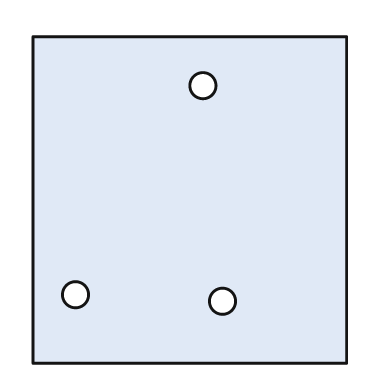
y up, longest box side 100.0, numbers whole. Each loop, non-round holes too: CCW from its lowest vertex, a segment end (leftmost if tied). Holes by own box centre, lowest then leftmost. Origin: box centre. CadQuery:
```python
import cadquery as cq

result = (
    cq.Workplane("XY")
    .moveTo(-48.0, -50.0)
    .lineTo(48.0, -50.0)
    .lineTo(48.0, 50.0)
    .lineTo(-48.0, 50.0)
    .close()
    .moveTo(10.0, -31.0)
    .circle(4.0)
    .moveTo(-35.0, -29.0)
    .circle(4.0)
    .moveTo(4.0, 35.0)
    .circle(4.0)
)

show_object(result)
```